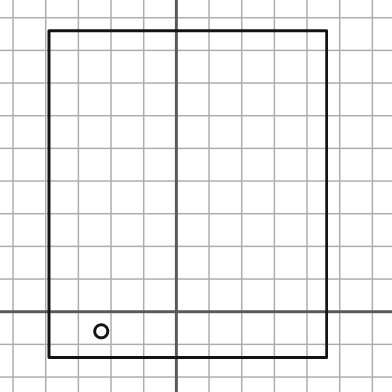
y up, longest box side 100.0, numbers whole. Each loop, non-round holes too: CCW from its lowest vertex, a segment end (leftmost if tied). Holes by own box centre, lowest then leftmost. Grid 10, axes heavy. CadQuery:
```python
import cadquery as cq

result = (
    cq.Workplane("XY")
    .moveTo(-39.0, -14.0)
    .lineTo(46.0, -14.0)
    .lineTo(46.0, 86.0)
    .lineTo(-39.0, 86.0)
    .close()
    .moveTo(-23.0, -6.0)
    .circle(2.0)
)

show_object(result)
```